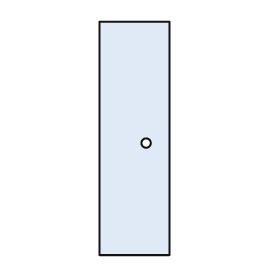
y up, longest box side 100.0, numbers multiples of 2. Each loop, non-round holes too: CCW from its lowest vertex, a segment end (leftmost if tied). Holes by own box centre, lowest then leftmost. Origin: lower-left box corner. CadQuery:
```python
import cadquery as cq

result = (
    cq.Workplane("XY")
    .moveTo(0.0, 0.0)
    .lineTo(30.0, 0.0)
    .lineTo(30.0, 100.0)
    .lineTo(0.0, 100.0)
    .close()
    .moveTo(20.0, 48.0)
    .circle(2.0)
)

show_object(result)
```